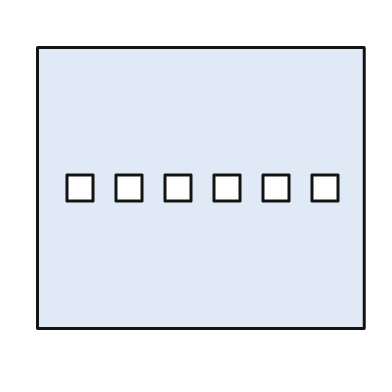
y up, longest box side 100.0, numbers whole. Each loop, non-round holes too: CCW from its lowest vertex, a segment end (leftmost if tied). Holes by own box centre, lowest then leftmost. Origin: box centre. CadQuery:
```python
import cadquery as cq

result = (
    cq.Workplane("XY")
    .moveTo(-50.0, -43.0)
    .lineTo(50.0, -43.0)
    .lineTo(50.0, 43.0)
    .lineTo(-50.0, 43.0)
    .close()
    .moveTo(-41.0, -4.0)
    .lineTo(-33.0, -4.0)
    .lineTo(-33.0, 4.0)
    .lineTo(-41.0, 4.0)
    .close()
    .moveTo(-26.0, -4.0)
    .lineTo(-18.0, -4.0)
    .lineTo(-18.0, 4.0)
    .lineTo(-26.0, 4.0)
    .close()
    .moveTo(-11.0, -4.0)
    .lineTo(-3.0, -4.0)
    .lineTo(-3.0, 4.0)
    .lineTo(-11.0, 4.0)
    .close()
    .moveTo(4.0, -4.0)
    .lineTo(12.0, -4.0)
    .lineTo(12.0, 4.0)
    .lineTo(4.0, 4.0)
    .close()
    .moveTo(19.0, -4.0)
    .lineTo(27.0, -4.0)
    .lineTo(27.0, 4.0)
    .lineTo(19.0, 4.0)
    .close()
    .moveTo(34.0, -4.0)
    .lineTo(42.0, -4.0)
    .lineTo(42.0, 4.0)
    .lineTo(34.0, 4.0)
    .close()
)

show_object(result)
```